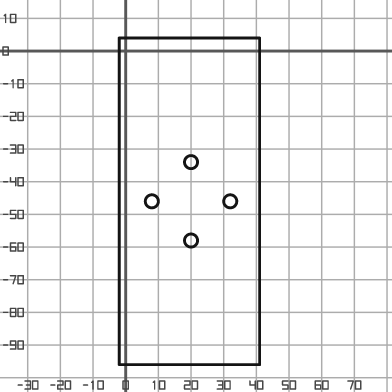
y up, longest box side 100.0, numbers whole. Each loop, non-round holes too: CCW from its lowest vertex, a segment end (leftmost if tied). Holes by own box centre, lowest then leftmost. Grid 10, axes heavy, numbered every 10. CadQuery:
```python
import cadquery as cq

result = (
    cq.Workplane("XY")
    .moveTo(-2.0, -96.0)
    .lineTo(41.0, -96.0)
    .lineTo(41.0, 4.0)
    .lineTo(-2.0, 4.0)
    .close()
    .moveTo(20.0, -58.0)
    .circle(2.0)
    .moveTo(8.0, -46.0)
    .circle(2.0)
    .moveTo(32.0, -46.0)
    .circle(2.0)
    .moveTo(20.0, -34.0)
    .circle(2.0)
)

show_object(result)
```